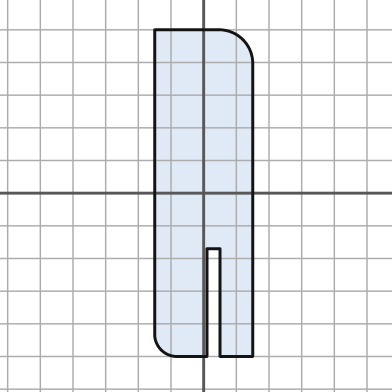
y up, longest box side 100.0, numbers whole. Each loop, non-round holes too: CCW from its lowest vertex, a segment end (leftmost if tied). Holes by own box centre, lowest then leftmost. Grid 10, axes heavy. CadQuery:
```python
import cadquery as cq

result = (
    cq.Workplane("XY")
    .moveTo(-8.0, -50.0)
    .lineTo(1.0, -50.0)
    .lineTo(1.0, -17.0)
    .lineTo(5.0, -17.0)
    .lineTo(5.0, -50.0)
    .lineTo(15.0, -50.0)
    .lineTo(15.0, 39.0)
    .threePointArc((12.0, 47.0), (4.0, 50.0))
    .lineTo(-15.0, 50.0)
    .lineTo(-15.0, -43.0)
    .threePointArc((-13.0, -48.0), (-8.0, -50.0))
    .close()
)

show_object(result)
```